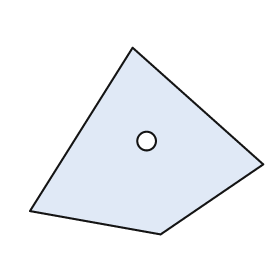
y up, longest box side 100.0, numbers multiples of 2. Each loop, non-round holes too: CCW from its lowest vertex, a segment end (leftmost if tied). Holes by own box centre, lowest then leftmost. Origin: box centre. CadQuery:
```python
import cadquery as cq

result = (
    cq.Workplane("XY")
    .moveTo(6.0, -40.0)
    .lineTo(50.0, -10.0)
    .lineTo(-6.0, 40.0)
    .lineTo(-50.0, -30.0)
    .close()
    .moveTo(0.0, 0.0)
    .circle(4.0)
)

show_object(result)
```